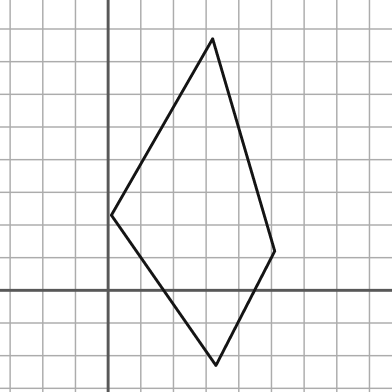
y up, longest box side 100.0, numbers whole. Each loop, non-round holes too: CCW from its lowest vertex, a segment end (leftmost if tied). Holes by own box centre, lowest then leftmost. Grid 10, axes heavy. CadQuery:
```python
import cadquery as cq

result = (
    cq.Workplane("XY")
    .moveTo(33.0, -23.0)
    .lineTo(51.0, 12.0)
    .lineTo(32.0, 77.0)
    .lineTo(1.0, 23.0)
    .close()
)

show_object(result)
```